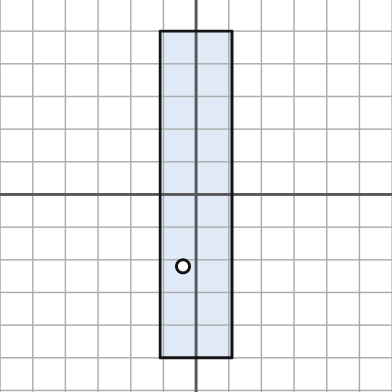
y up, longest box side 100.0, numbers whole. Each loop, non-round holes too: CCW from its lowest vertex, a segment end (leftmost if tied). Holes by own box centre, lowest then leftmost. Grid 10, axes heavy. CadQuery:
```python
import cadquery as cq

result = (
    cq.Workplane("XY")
    .moveTo(-11.0, -50.0)
    .lineTo(11.0, -50.0)
    .lineTo(11.0, 50.0)
    .lineTo(-11.0, 50.0)
    .close()
    .moveTo(-4.0, -22.0)
    .circle(2.0)
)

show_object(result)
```